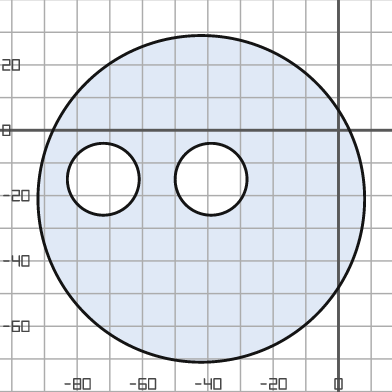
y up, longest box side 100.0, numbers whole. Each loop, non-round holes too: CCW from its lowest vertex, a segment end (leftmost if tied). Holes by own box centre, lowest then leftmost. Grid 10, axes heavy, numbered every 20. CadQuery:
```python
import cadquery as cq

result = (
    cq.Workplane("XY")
    .moveTo(-42.0, -21.0)
    .circle(50.0)
    .moveTo(-72.0, -15.0)
    .circle(11.0)
    .moveTo(-39.0, -15.0)
    .circle(11.0)
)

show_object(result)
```